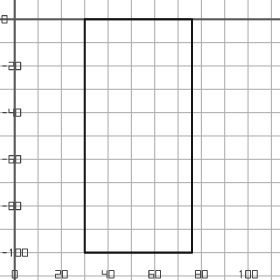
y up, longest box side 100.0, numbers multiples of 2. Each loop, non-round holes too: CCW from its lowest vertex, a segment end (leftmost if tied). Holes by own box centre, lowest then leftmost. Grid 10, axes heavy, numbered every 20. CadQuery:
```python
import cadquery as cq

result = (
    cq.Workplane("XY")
    .moveTo(30.0, -100.0)
    .lineTo(76.0, -100.0)
    .lineTo(76.0, 0.0)
    .lineTo(30.0, 0.0)
    .close()
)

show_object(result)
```